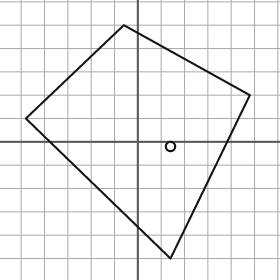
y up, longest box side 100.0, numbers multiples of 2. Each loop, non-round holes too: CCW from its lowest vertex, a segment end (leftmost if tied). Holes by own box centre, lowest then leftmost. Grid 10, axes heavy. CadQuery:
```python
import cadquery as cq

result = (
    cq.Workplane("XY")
    .moveTo(14.0, -50.0)
    .lineTo(48.0, 20.0)
    .lineTo(-6.0, 50.0)
    .lineTo(-48.0, 10.0)
    .close()
    .moveTo(14.0, -2.0)
    .circle(2.0)
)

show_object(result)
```